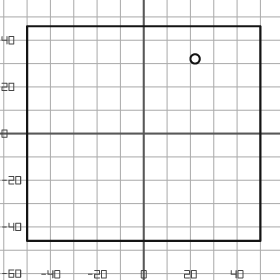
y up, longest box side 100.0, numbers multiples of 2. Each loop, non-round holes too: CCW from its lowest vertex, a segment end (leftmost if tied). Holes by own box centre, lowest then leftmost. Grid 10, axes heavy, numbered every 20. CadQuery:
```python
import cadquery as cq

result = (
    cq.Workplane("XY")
    .moveTo(-50.0, -46.0)
    .lineTo(50.0, -46.0)
    .lineTo(50.0, 46.0)
    .lineTo(-50.0, 46.0)
    .close()
    .moveTo(22.0, 32.0)
    .circle(2.0)
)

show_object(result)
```